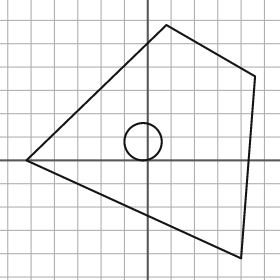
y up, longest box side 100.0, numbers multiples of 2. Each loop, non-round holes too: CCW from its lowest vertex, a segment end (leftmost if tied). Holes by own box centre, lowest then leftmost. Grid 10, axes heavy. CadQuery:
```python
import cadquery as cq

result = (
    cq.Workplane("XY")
    .moveTo(40.0, -42.0)
    .lineTo(46.0, 36.0)
    .lineTo(8.0, 58.0)
    .lineTo(-52.0, 0.0)
    .close()
    .moveTo(-2.0, 8.0)
    .circle(8.0)
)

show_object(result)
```